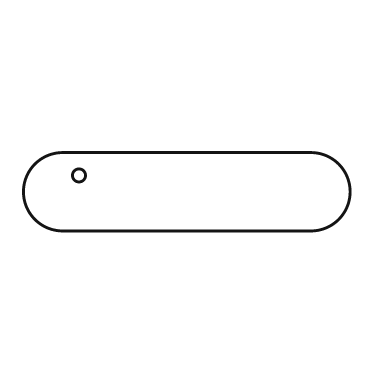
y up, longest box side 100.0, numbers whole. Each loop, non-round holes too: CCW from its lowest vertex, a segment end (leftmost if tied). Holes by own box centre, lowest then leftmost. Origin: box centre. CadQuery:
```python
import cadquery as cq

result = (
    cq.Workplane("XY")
    .moveTo(-38.0, -12.0)
    .lineTo(38.0, -12.0)
    .threePointArc((50.0, 0.0), (38.0, 12.0))
    .lineTo(-38.0, 12.0)
    .threePointArc((-50.0, 0.0), (-38.0, -12.0))
    .close()
    .moveTo(-33.0, 5.0)
    .circle(2.0)
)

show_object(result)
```